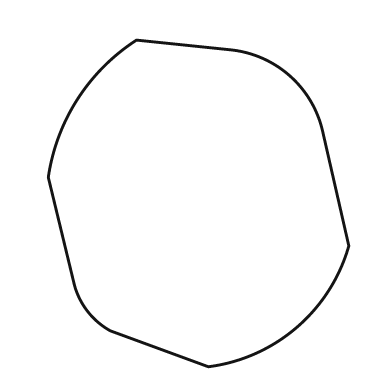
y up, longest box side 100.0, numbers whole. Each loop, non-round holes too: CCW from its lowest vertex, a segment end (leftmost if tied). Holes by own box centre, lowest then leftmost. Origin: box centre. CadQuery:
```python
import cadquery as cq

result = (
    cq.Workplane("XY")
    .moveTo(3.0, -50.0)
    .threePointArc((30.0, -38.0), (46.0, -13.0))
    .lineTo(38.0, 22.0)
    .threePointArc((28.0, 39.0), (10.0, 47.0))
    .lineTo(-19.0, 50.0)
    .threePointArc((-37.0, 32.0), (-46.0, 8.0))
    .lineTo(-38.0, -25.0)
    .threePointArc((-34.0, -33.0), (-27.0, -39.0))
    .close()
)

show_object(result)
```